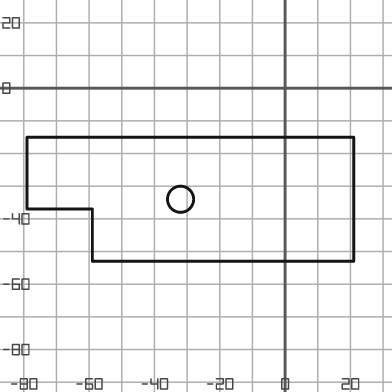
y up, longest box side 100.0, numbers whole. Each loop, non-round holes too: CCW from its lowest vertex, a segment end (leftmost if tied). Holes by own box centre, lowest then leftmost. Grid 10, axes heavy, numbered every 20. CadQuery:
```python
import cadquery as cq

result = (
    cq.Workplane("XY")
    .moveTo(-59.0, -53.0)
    .lineTo(21.0, -53.0)
    .lineTo(21.0, -15.0)
    .lineTo(-79.0, -15.0)
    .lineTo(-79.0, -37.0)
    .lineTo(-59.0, -37.0)
    .close()
    .moveTo(-32.0, -34.0)
    .circle(4.0)
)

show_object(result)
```